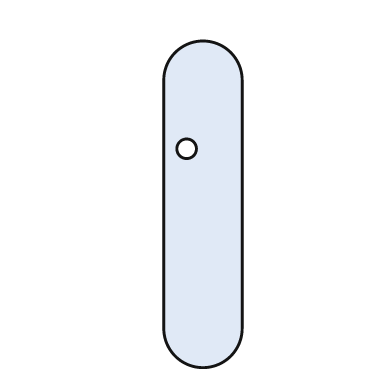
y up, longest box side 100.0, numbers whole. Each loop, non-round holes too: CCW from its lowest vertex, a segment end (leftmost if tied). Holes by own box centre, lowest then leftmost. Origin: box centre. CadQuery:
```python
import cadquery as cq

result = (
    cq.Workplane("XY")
    .moveTo(-12.0, -38.0)
    .threePointArc((0.0, -50.0), (12.0, -38.0))
    .lineTo(12.0, 38.0)
    .threePointArc((0.0, 50.0), (-12.0, 38.0))
    .close()
    .moveTo(-5.0, 17.0)
    .circle(3.0)
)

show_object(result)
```